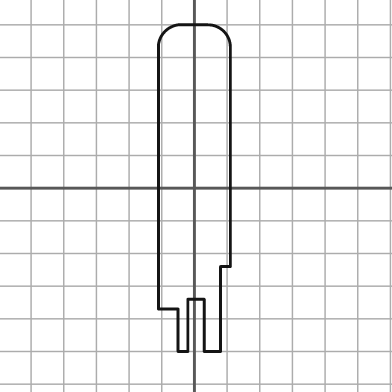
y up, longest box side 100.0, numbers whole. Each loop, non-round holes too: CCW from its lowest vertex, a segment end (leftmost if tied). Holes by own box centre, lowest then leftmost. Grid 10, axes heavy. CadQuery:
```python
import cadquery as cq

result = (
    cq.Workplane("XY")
    .moveTo(-5.0, -50.0)
    .lineTo(-2.0, -50.0)
    .lineTo(-2.0, -34.0)
    .lineTo(3.0, -34.0)
    .lineTo(3.0, -50.0)
    .lineTo(8.0, -50.0)
    .lineTo(8.0, -24.0)
    .lineTo(11.0, -24.0)
    .lineTo(11.0, 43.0)
    .threePointArc((9.0, 48.0), (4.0, 50.0))
    .lineTo(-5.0, 50.0)
    .threePointArc((-9.0, 48.0), (-11.0, 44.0))
    .lineTo(-11.0, -37.0)
    .lineTo(-5.0, -37.0)
    .close()
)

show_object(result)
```